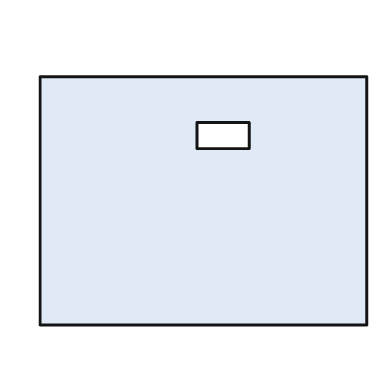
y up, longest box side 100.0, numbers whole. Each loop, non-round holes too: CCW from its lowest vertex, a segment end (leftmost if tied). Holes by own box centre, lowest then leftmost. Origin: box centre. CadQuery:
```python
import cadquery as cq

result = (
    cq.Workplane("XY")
    .moveTo(-50.0, -38.0)
    .lineTo(50.0, -38.0)
    .lineTo(50.0, 38.0)
    .lineTo(-50.0, 38.0)
    .close()
    .moveTo(-2.0, 16.0)
    .lineTo(14.0, 16.0)
    .lineTo(14.0, 24.0)
    .lineTo(-2.0, 24.0)
    .close()
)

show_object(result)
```